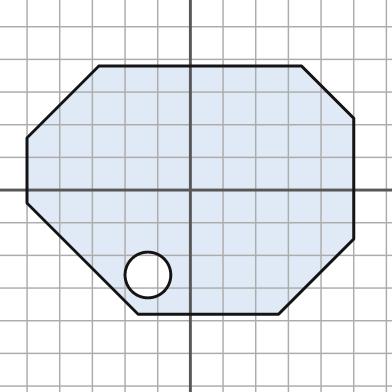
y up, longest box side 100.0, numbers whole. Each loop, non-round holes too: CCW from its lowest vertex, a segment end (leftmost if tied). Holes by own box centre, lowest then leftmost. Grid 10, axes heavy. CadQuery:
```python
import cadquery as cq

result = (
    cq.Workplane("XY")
    .moveTo(-16.0, -38.0)
    .lineTo(27.0, -38.0)
    .lineTo(50.0, -15.0)
    .lineTo(50.0, 22.0)
    .lineTo(34.0, 38.0)
    .lineTo(-28.0, 38.0)
    .lineTo(-50.0, 16.0)
    .lineTo(-50.0, -4.0)
    .close()
    .moveTo(-13.0, -26.0)
    .circle(7.0)
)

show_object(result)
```